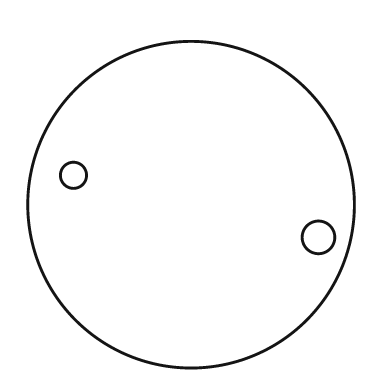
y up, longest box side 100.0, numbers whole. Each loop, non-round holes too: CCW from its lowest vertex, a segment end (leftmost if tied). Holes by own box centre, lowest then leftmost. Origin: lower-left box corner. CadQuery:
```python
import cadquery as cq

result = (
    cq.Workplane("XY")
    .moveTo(50.0, 50.0)
    .circle(50.0)
    .moveTo(89.0, 40.0)
    .circle(5.0)
    .moveTo(14.0, 59.0)
    .circle(4.0)
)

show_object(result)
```